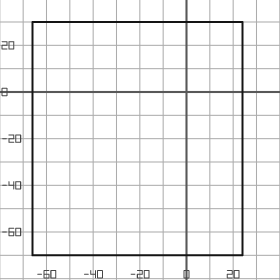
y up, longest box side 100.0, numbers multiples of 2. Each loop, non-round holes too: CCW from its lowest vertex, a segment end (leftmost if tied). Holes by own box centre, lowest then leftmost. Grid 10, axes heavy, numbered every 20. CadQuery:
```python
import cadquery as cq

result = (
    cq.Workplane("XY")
    .moveTo(-66.0, -70.0)
    .lineTo(24.0, -70.0)
    .lineTo(24.0, 30.0)
    .lineTo(-66.0, 30.0)
    .close()
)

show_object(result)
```